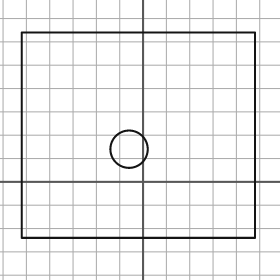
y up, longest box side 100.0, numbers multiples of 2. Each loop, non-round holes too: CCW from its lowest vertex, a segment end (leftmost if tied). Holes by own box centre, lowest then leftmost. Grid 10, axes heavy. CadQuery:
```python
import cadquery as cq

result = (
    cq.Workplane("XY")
    .moveTo(-52.0, -24.0)
    .lineTo(48.0, -24.0)
    .lineTo(48.0, 64.0)
    .lineTo(-52.0, 64.0)
    .close()
    .moveTo(-6.0, 14.0)
    .circle(8.0)
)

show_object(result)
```